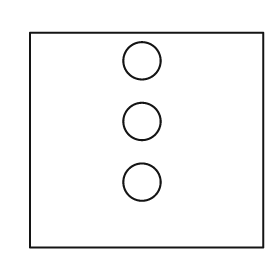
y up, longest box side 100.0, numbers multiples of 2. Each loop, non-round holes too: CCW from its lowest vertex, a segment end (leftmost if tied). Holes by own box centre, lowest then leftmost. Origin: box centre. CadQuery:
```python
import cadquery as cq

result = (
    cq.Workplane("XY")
    .moveTo(-50.0, -46.0)
    .lineTo(50.0, -46.0)
    .lineTo(50.0, 46.0)
    .lineTo(-50.0, 46.0)
    .close()
    .moveTo(-2.0, -18.0)
    .circle(8.0)
    .moveTo(-2.0, 8.0)
    .circle(8.0)
    .moveTo(-2.0, 34.0)
    .circle(8.0)
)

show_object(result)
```